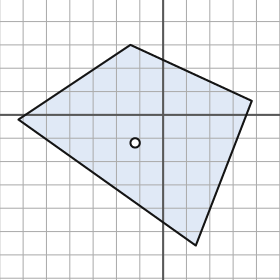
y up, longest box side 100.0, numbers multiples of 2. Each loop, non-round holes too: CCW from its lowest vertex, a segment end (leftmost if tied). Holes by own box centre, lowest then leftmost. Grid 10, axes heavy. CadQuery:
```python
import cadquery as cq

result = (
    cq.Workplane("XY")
    .moveTo(14.0, -56.0)
    .lineTo(38.0, 6.0)
    .lineTo(-14.0, 30.0)
    .lineTo(-62.0, -2.0)
    .close()
    .moveTo(-12.0, -12.0)
    .circle(2.0)
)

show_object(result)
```